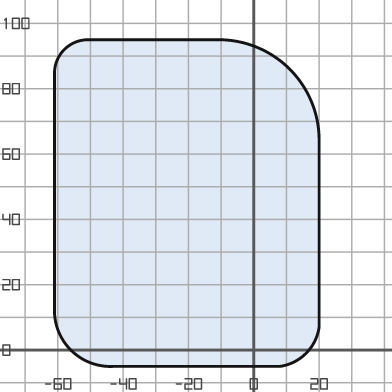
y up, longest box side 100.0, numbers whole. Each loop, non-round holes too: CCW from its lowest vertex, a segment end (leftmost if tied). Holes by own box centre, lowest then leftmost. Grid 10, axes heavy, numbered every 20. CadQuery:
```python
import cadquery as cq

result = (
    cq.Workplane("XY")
    .moveTo(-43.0, -5.0)
    .lineTo(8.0, -5.0)
    .threePointArc((16.0, -1.0), (20.0, 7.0))
    .lineTo(20.0, 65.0)
    .threePointArc((11.0, 86.0), (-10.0, 95.0))
    .lineTo(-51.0, 95.0)
    .threePointArc((-58.0, 92.0), (-61.0, 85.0))
    .lineTo(-61.0, 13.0)
    .threePointArc((-56.0, 0.0), (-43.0, -5.0))
    .close()
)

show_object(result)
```